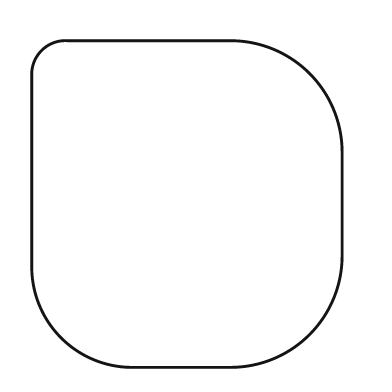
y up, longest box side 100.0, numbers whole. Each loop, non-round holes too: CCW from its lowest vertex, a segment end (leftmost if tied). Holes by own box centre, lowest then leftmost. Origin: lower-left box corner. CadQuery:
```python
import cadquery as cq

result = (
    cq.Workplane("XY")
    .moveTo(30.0, 0.0)
    .lineTo(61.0, 0.0)
    .threePointArc((85.0, 10.0), (95.0, 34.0))
    .lineTo(95.0, 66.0)
    .threePointArc((85.0, 90.0), (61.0, 100.0))
    .lineTo(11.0, 100.0)
    .threePointArc((3.0, 97.0), (0.0, 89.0))
    .lineTo(0.0, 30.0)
    .threePointArc((9.0, 9.0), (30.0, 0.0))
    .close()
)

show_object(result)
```